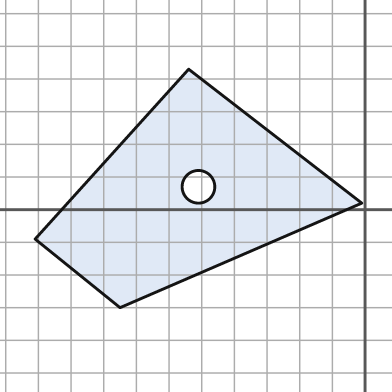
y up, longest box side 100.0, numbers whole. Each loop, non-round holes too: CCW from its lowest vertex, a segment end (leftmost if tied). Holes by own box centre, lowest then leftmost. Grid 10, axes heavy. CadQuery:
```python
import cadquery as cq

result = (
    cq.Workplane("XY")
    .moveTo(-75.0, -30.0)
    .lineTo(-1.0, 2.0)
    .lineTo(-54.0, 43.0)
    .lineTo(-101.0, -9.0)
    .close()
    .moveTo(-51.0, 7.0)
    .circle(5.0)
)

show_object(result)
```